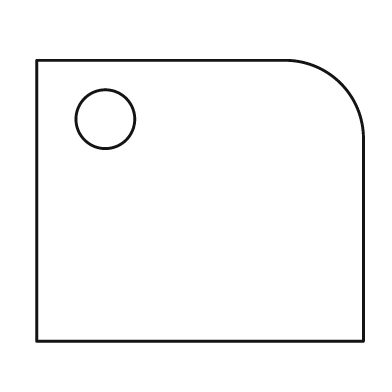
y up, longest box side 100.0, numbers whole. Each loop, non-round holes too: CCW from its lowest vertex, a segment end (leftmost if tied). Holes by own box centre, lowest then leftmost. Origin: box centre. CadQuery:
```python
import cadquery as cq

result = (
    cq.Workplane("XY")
    .moveTo(-50.0, -43.0)
    .lineTo(50.0, -43.0)
    .lineTo(50.0, 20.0)
    .threePointArc((43.0, 36.0), (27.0, 43.0))
    .lineTo(-50.0, 43.0)
    .close()
    .moveTo(-29.0, 25.0)
    .circle(9.0)
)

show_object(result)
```